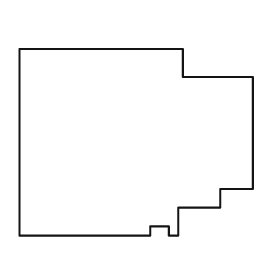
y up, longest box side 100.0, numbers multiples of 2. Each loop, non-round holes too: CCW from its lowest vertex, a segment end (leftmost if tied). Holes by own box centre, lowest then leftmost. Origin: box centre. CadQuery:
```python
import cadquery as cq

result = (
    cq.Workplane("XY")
    .moveTo(-50.0, -40.0)
    .lineTo(6.0, -40.0)
    .lineTo(6.0, -36.0)
    .lineTo(14.0, -36.0)
    .lineTo(14.0, -40.0)
    .lineTo(18.0, -40.0)
    .lineTo(18.0, -28.0)
    .lineTo(36.0, -28.0)
    .lineTo(36.0, -20.0)
    .lineTo(50.0, -20.0)
    .lineTo(50.0, 28.0)
    .lineTo(20.0, 28.0)
    .lineTo(20.0, 40.0)
    .lineTo(-50.0, 40.0)
    .close()
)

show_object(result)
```